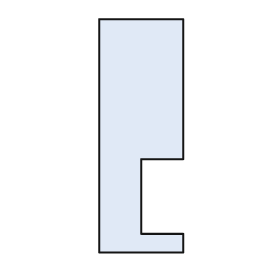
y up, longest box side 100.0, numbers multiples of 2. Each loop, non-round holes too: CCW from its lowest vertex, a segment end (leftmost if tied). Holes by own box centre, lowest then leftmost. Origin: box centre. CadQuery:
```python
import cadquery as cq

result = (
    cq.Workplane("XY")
    .moveTo(-18.0, -50.0)
    .lineTo(18.0, -50.0)
    .lineTo(18.0, -42.0)
    .lineTo(0.0, -42.0)
    .lineTo(0.0, -10.0)
    .lineTo(18.0, -10.0)
    .lineTo(18.0, 50.0)
    .lineTo(-18.0, 50.0)
    .close()
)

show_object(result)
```